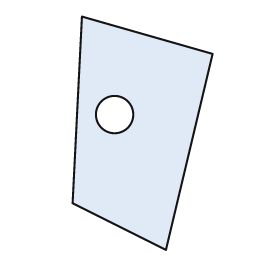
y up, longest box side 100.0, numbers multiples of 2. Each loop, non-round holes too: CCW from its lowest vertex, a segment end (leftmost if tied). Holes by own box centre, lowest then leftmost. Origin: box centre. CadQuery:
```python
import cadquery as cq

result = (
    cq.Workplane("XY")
    .moveTo(10.0, -50.0)
    .lineTo(30.0, 34.0)
    .lineTo(-26.0, 50.0)
    .lineTo(-30.0, -30.0)
    .close()
    .moveTo(-12.0, 8.0)
    .circle(8.0)
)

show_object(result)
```